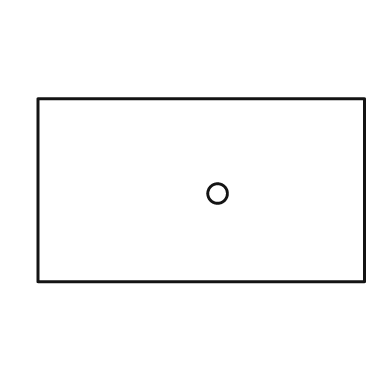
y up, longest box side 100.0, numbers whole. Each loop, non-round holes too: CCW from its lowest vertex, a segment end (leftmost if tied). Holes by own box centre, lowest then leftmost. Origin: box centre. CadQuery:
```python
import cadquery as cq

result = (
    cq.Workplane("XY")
    .moveTo(-50.0, -28.0)
    .lineTo(50.0, -28.0)
    .lineTo(50.0, 28.0)
    .lineTo(-50.0, 28.0)
    .close()
    .moveTo(5.0, -1.0)
    .circle(3.0)
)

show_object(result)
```